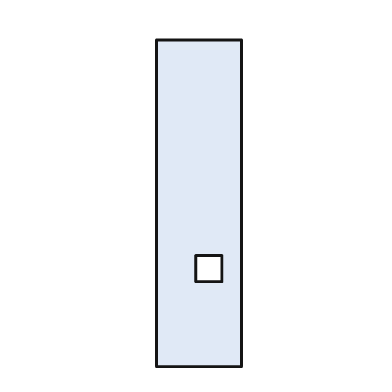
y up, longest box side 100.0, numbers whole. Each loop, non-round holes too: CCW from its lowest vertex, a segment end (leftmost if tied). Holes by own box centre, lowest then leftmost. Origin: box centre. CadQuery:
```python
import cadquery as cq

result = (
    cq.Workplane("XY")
    .moveTo(-13.0, -50.0)
    .lineTo(13.0, -50.0)
    .lineTo(13.0, 50.0)
    .lineTo(-13.0, 50.0)
    .close()
    .moveTo(-1.0, -24.0)
    .lineTo(7.0, -24.0)
    .lineTo(7.0, -16.0)
    .lineTo(-1.0, -16.0)
    .close()
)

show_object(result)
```